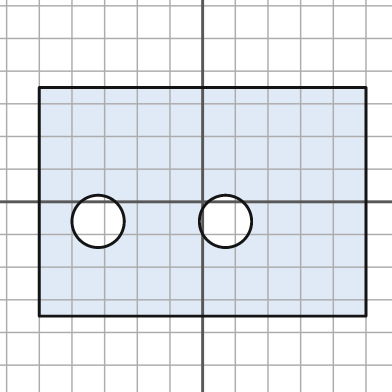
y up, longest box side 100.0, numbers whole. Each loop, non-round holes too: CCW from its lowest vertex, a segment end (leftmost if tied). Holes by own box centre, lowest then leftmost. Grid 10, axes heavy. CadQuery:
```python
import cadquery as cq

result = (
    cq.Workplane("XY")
    .moveTo(-50.0, -35.0)
    .lineTo(50.0, -35.0)
    .lineTo(50.0, 35.0)
    .lineTo(-50.0, 35.0)
    .close()
    .moveTo(-32.0, -6.0)
    .circle(8.0)
    .moveTo(7.0, -6.0)
    .circle(8.0)
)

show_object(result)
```